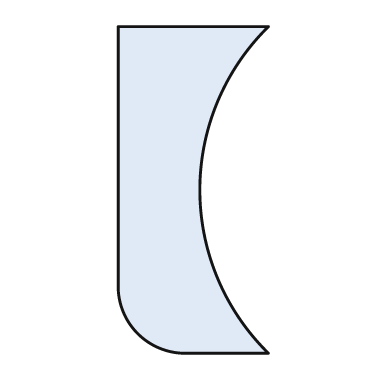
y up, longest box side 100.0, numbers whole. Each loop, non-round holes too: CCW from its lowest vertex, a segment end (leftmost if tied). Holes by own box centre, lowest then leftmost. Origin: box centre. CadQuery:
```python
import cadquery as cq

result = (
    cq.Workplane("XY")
    .moveTo(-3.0, -50.0)
    .lineTo(23.0, -50.0)
    .threePointArc((2.0, 0.0), (23.0, 50.0))
    .lineTo(-23.0, 50.0)
    .lineTo(-23.0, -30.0)
    .threePointArc((-17.0, -44.0), (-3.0, -50.0))
    .close()
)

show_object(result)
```